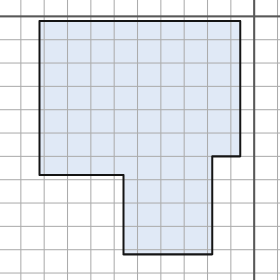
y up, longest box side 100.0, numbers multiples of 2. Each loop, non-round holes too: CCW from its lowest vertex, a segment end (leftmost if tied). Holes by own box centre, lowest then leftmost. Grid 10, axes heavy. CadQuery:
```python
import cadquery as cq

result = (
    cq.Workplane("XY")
    .moveTo(-56.0, -102.0)
    .lineTo(-18.0, -102.0)
    .lineTo(-18.0, -60.0)
    .lineTo(-6.0, -60.0)
    .lineTo(-6.0, -2.0)
    .lineTo(-92.0, -2.0)
    .lineTo(-92.0, -68.0)
    .lineTo(-56.0, -68.0)
    .close()
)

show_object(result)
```